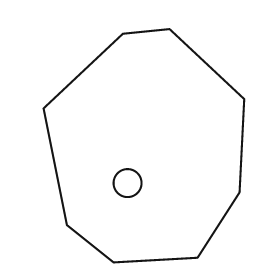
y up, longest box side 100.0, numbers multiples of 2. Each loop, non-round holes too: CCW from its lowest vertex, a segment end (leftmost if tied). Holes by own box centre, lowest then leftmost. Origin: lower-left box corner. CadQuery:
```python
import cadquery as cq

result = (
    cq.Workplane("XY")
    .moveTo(30.0, 0.0)
    .lineTo(66.0, 2.0)
    .lineTo(84.0, 30.0)
    .lineTo(86.0, 70.0)
    .lineTo(54.0, 100.0)
    .lineTo(34.0, 98.0)
    .lineTo(0.0, 66.0)
    .lineTo(10.0, 16.0)
    .close()
    .moveTo(36.0, 34.0)
    .circle(6.0)
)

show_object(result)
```